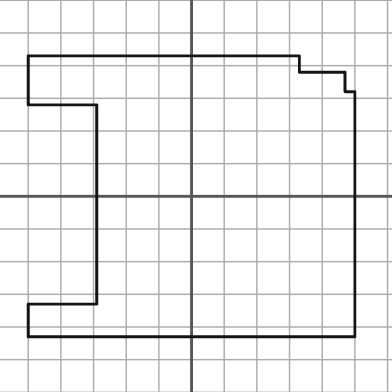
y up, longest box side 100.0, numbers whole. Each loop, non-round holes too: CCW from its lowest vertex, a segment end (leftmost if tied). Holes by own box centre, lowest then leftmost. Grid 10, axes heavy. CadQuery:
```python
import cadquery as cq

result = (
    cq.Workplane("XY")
    .moveTo(-50.0, -43.0)
    .lineTo(50.0, -43.0)
    .lineTo(50.0, 32.0)
    .lineTo(47.0, 32.0)
    .lineTo(47.0, 38.0)
    .lineTo(33.0, 38.0)
    .lineTo(33.0, 43.0)
    .lineTo(-50.0, 43.0)
    .lineTo(-50.0, 28.0)
    .lineTo(-29.0, 28.0)
    .lineTo(-29.0, -33.0)
    .lineTo(-50.0, -33.0)
    .close()
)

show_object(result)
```